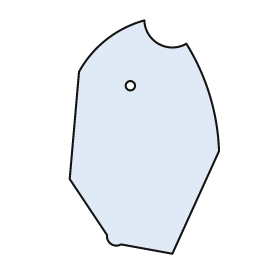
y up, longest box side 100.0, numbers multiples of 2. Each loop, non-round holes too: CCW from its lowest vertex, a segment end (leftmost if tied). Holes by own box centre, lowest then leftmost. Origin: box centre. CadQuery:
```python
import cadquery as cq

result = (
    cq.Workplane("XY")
    .moveTo(12.0, -50.0)
    .lineTo(32.0, -6.0)
    .threePointArc((28.0, 18.0), (18.0, 40.0))
    .threePointArc((6.0, 40.0), (0.0, 50.0))
    .threePointArc((-16.0, 42.0), (-28.0, 28.0))
    .lineTo(-32.0, -18.0)
    .lineTo(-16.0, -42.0)
    .threePointArc((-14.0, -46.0), (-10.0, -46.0))
    .close()
    .moveTo(-6.0, 22.0)
    .circle(2.0)
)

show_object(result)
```